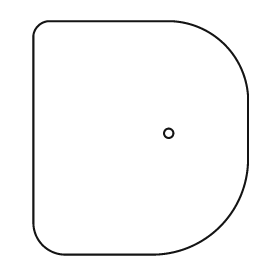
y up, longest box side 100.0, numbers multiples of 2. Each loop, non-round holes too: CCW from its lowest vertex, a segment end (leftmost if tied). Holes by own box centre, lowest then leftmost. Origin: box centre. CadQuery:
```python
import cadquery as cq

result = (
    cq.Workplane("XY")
    .moveTo(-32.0, -50.0)
    .lineTo(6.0, -50.0)
    .threePointArc((34.0, -38.0), (46.0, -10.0))
    .lineTo(46.0, 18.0)
    .threePointArc((36.0, 40.0), (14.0, 50.0))
    .lineTo(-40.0, 50.0)
    .threePointArc((-44.0, 48.0), (-46.0, 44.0))
    .lineTo(-46.0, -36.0)
    .threePointArc((-42.0, -46.0), (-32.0, -50.0))
    .close()
    .moveTo(12.0, 2.0)
    .circle(2.0)
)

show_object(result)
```